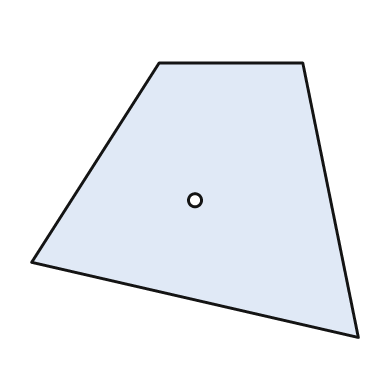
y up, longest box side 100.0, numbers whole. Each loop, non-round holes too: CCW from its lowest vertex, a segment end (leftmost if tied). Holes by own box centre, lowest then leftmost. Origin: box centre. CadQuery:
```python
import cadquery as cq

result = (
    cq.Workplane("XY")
    .moveTo(50.0, -42.0)
    .lineTo(33.0, 42.0)
    .lineTo(-11.0, 42.0)
    .lineTo(-50.0, -19.0)
    .close()
    .moveTo(0.0, 0.0)
    .circle(2.0)
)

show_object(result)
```